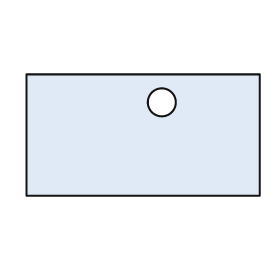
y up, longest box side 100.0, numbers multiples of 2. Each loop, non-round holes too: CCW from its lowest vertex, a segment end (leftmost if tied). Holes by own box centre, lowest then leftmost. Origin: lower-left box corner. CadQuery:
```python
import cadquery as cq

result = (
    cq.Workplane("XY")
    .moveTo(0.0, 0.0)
    .lineTo(100.0, 0.0)
    .lineTo(100.0, 52.0)
    .lineTo(0.0, 52.0)
    .close()
    .moveTo(58.0, 40.0)
    .circle(6.0)
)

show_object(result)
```